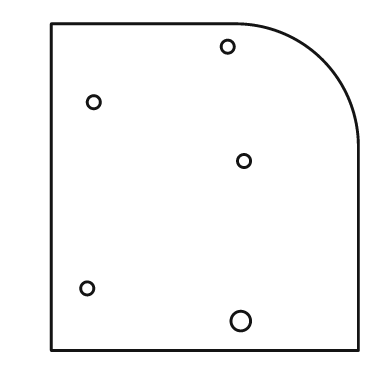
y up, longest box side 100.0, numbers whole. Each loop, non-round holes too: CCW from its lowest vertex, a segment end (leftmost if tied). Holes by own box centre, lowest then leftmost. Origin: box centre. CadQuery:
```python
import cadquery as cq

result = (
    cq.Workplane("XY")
    .moveTo(-47.0, -50.0)
    .lineTo(47.0, -50.0)
    .lineTo(47.0, 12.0)
    .threePointArc((36.0, 39.0), (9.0, 50.0))
    .lineTo(-47.0, 50.0)
    .close()
    .moveTo(11.0, -41.0)
    .circle(3.0)
    .moveTo(-36.0, -31.0)
    .circle(2.0)
    .moveTo(12.0, 8.0)
    .circle(2.0)
    .moveTo(-34.0, 26.0)
    .circle(2.0)
    .moveTo(7.0, 43.0)
    .circle(2.0)
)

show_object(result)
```